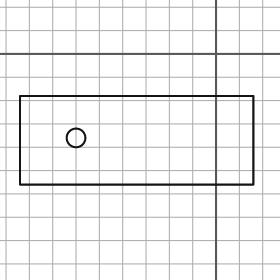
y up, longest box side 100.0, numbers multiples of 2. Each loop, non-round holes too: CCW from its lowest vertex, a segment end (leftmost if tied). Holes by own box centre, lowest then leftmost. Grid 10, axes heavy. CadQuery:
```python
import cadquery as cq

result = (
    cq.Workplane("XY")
    .moveTo(-84.0, -56.0)
    .lineTo(16.0, -56.0)
    .lineTo(16.0, -18.0)
    .lineTo(-84.0, -18.0)
    .close()
    .moveTo(-60.0, -36.0)
    .circle(4.0)
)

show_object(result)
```